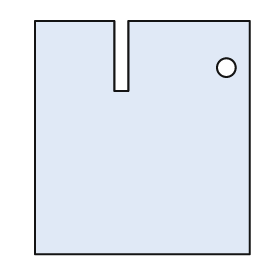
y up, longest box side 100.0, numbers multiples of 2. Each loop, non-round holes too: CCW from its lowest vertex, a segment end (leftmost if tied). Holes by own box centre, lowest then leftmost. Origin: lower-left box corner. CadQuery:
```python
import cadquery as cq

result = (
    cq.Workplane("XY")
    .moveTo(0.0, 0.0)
    .lineTo(92.0, 0.0)
    .lineTo(92.0, 100.0)
    .lineTo(40.0, 100.0)
    .lineTo(40.0, 70.0)
    .lineTo(34.0, 70.0)
    .lineTo(34.0, 100.0)
    .lineTo(0.0, 100.0)
    .close()
    .moveTo(82.0, 80.0)
    .circle(4.0)
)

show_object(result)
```